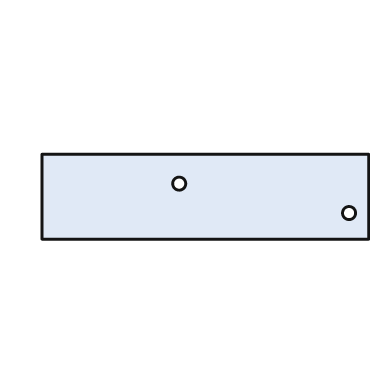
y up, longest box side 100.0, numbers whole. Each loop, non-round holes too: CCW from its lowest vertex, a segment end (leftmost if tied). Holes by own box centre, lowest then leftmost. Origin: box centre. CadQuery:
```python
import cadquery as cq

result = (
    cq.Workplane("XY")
    .moveTo(-50.0, -13.0)
    .lineTo(50.0, -13.0)
    .lineTo(50.0, 13.0)
    .lineTo(-50.0, 13.0)
    .close()
    .moveTo(44.0, -5.0)
    .circle(2.0)
    .moveTo(-8.0, 4.0)
    .circle(2.0)
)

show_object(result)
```